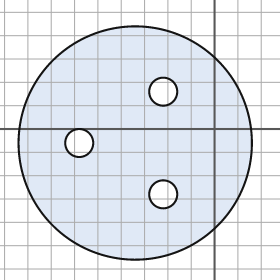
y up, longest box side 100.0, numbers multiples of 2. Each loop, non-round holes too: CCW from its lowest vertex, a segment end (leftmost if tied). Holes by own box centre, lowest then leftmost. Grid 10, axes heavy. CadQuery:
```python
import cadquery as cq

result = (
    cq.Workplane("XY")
    .moveTo(-34.0, -6.0)
    .circle(50.0)
    .moveTo(-22.0, -28.0)
    .circle(6.0)
    .moveTo(-58.0, -6.0)
    .circle(6.0)
    .moveTo(-22.0, 16.0)
    .circle(6.0)
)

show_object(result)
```